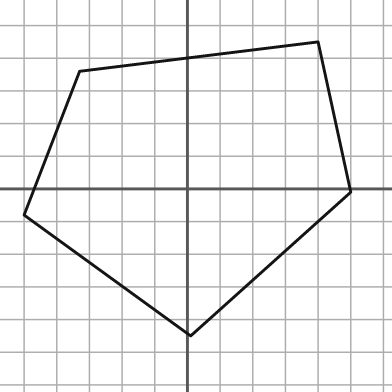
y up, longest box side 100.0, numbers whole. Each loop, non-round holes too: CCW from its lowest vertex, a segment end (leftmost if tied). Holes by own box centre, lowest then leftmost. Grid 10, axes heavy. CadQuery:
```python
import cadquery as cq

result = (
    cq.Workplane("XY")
    .moveTo(1.0, -45.0)
    .lineTo(50.0, -1.0)
    .lineTo(40.0, 45.0)
    .lineTo(-33.0, 36.0)
    .lineTo(-50.0, -8.0)
    .close()
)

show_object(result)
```